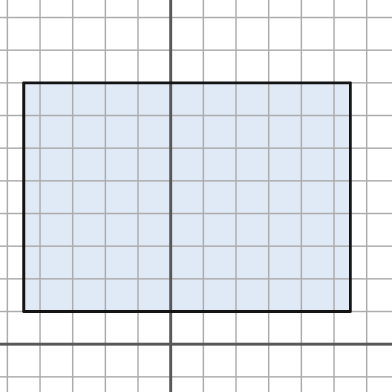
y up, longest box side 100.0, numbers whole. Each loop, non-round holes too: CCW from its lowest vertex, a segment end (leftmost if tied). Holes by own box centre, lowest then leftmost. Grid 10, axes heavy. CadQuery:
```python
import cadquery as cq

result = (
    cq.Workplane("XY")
    .moveTo(-45.0, 10.0)
    .lineTo(55.0, 10.0)
    .lineTo(55.0, 80.0)
    .lineTo(-45.0, 80.0)
    .close()
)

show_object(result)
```